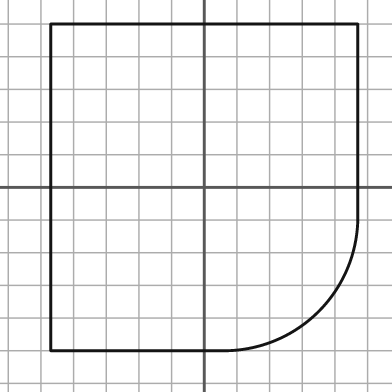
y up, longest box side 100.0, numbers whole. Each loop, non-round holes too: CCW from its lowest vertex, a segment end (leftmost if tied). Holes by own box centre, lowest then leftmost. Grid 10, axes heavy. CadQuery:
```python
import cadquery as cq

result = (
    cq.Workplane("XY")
    .moveTo(-47.0, -50.0)
    .lineTo(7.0, -50.0)
    .threePointArc((35.0, -38.0), (47.0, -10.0))
    .lineTo(47.0, 50.0)
    .lineTo(-47.0, 50.0)
    .close()
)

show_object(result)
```